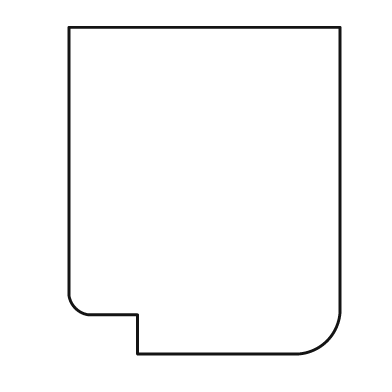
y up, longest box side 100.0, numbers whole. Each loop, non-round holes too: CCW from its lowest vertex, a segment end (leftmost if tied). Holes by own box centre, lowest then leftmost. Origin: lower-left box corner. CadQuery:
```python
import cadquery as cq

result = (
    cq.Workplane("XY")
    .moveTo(21.0, 0.0)
    .lineTo(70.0, 0.0)
    .threePointArc((79.0, 4.0), (83.0, 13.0))
    .lineTo(83.0, 100.0)
    .lineTo(0.0, 100.0)
    .lineTo(0.0, 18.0)
    .threePointArc((2.0, 14.0), (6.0, 12.0))
    .lineTo(21.0, 12.0)
    .close()
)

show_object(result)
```